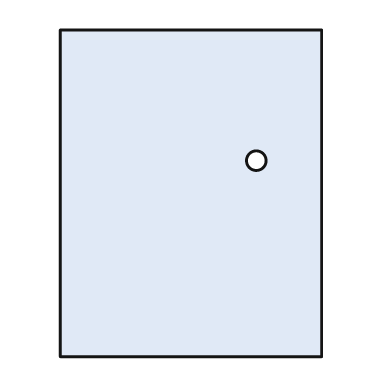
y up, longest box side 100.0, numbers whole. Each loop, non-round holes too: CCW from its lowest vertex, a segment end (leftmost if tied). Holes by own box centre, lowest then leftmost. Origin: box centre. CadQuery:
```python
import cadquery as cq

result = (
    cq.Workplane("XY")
    .moveTo(-40.0, -50.0)
    .lineTo(40.0, -50.0)
    .lineTo(40.0, 50.0)
    .lineTo(-40.0, 50.0)
    .close()
    .moveTo(20.0, 10.0)
    .circle(3.0)
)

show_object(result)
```